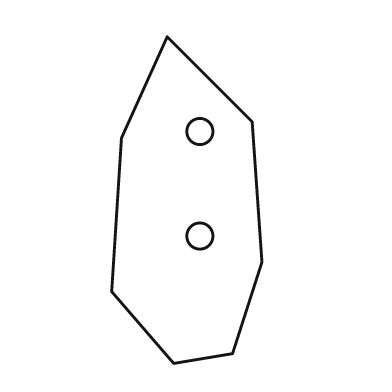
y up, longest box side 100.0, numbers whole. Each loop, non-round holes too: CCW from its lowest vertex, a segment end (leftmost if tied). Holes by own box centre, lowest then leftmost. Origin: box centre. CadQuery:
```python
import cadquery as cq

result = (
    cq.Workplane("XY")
    .moveTo(-4.0, -50.0)
    .lineTo(14.0, -47.0)
    .lineTo(23.0, -19.0)
    .lineTo(20.0, 24.0)
    .lineTo(-6.0, 50.0)
    .lineTo(-20.0, 19.0)
    .lineTo(-23.0, -28.0)
    .close()
    .moveTo(4.0, -11.0)
    .circle(4.0)
    .moveTo(4.0, 21.0)
    .circle(4.0)
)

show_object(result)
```